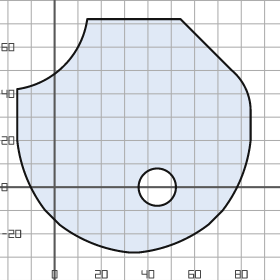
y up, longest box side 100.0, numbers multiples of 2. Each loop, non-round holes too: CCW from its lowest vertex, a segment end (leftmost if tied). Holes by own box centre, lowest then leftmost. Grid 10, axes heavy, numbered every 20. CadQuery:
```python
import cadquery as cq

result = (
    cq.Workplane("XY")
    .moveTo(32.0, -28.0)
    .lineTo(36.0, -28.0)
    .threePointArc((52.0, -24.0), (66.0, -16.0))
    .lineTo(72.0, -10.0)
    .threePointArc((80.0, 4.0), (84.0, 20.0))
    .lineTo(84.0, 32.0)
    .threePointArc((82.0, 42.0), (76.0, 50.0))
    .lineTo(54.0, 72.0)
    .lineTo(14.0, 72.0)
    .threePointArc((4.0, 52.0), (-16.0, 42.0))
    .lineTo(-16.0, 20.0)
    .threePointArc((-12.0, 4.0), (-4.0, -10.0))
    .lineTo(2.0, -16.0)
    .threePointArc((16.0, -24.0), (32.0, -28.0))
    .close()
    .moveTo(44.0, 0.0)
    .circle(8.0)
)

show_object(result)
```